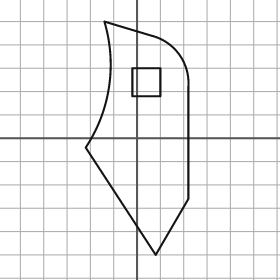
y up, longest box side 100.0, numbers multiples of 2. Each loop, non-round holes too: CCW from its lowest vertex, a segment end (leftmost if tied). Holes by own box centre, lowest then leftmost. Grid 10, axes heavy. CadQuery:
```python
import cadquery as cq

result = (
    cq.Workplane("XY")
    .moveTo(8.0, -50.0)
    .lineTo(22.0, -26.0)
    .lineTo(22.0, 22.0)
    .threePointArc((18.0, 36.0), (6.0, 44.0))
    .lineTo(-14.0, 50.0)
    .threePointArc((-12.0, 22.0), (-22.0, -4.0))
    .close()
    .moveTo(-2.0, 18.0)
    .lineTo(10.0, 18.0)
    .lineTo(10.0, 30.0)
    .lineTo(-2.0, 30.0)
    .close()
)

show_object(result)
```